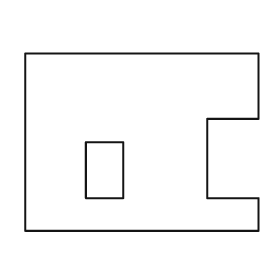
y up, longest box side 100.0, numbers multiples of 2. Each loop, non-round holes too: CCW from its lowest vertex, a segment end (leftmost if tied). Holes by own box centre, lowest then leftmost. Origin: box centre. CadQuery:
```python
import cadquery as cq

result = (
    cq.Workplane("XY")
    .moveTo(-50.0, -38.0)
    .lineTo(50.0, -38.0)
    .lineTo(50.0, -24.0)
    .lineTo(28.0, -24.0)
    .lineTo(28.0, 10.0)
    .lineTo(50.0, 10.0)
    .lineTo(50.0, 38.0)
    .lineTo(-50.0, 38.0)
    .close()
    .moveTo(-24.0, -24.0)
    .lineTo(-8.0, -24.0)
    .lineTo(-8.0, 0.0)
    .lineTo(-24.0, 0.0)
    .close()
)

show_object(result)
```